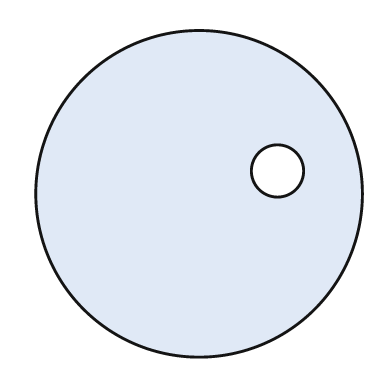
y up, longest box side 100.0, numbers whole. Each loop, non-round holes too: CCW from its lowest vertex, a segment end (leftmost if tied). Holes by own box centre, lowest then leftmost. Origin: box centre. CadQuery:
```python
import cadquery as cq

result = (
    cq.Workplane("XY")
    .moveTo(0.0, 0.0)
    .circle(50.0)
    .moveTo(24.0, 7.0)
    .circle(8.0)
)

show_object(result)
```